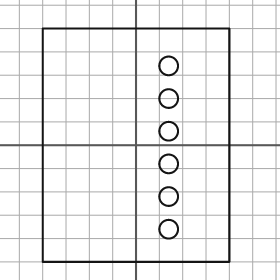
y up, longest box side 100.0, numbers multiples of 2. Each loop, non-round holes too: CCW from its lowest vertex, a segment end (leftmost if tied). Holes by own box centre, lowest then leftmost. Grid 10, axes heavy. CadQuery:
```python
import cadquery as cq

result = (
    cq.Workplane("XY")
    .moveTo(-40.0, -50.0)
    .lineTo(40.0, -50.0)
    .lineTo(40.0, 50.0)
    .lineTo(-40.0, 50.0)
    .close()
    .moveTo(14.0, -36.0)
    .circle(4.0)
    .moveTo(14.0, -22.0)
    .circle(4.0)
    .moveTo(14.0, -8.0)
    .circle(4.0)
    .moveTo(14.0, 6.0)
    .circle(4.0)
    .moveTo(14.0, 20.0)
    .circle(4.0)
    .moveTo(14.0, 34.0)
    .circle(4.0)
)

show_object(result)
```